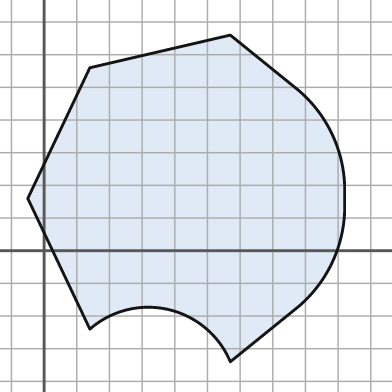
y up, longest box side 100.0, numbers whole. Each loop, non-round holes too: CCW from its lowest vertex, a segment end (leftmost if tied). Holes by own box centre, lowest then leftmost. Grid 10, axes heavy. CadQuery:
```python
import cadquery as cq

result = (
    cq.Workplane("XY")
    .moveTo(57.0, -34.0)
    .lineTo(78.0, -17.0)
    .threePointArc((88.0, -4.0), (92.0, 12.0))
    .lineTo(92.0, 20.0)
    .threePointArc((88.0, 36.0), (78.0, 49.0))
    .lineTo(57.0, 66.0)
    .lineTo(14.0, 56.0)
    .lineTo(-5.0, 16.0)
    .lineTo(14.0, -24.0)
    .threePointArc((38.0, -18.0), (57.0, -34.0))
    .close()
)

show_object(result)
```